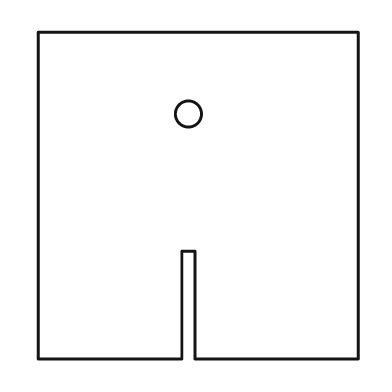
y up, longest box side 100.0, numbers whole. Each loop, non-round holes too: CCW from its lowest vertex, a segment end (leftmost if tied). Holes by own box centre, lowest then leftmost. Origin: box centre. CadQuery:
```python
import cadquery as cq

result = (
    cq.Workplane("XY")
    .moveTo(-49.0, -50.0)
    .lineTo(-5.0, -50.0)
    .lineTo(-5.0, -17.0)
    .lineTo(-1.0, -17.0)
    .lineTo(-1.0, -50.0)
    .lineTo(49.0, -50.0)
    .lineTo(49.0, 50.0)
    .lineTo(-49.0, 50.0)
    .close()
    .moveTo(-3.0, 25.0)
    .circle(4.0)
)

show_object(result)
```